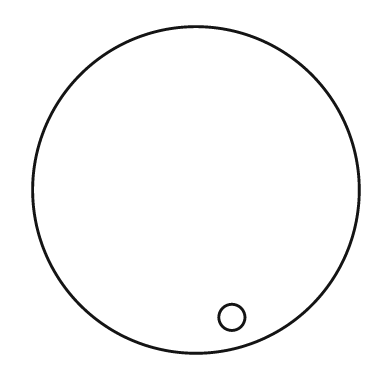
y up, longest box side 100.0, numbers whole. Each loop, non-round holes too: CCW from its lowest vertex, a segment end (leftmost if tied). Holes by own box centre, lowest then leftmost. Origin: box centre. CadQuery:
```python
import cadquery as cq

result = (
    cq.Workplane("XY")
    .moveTo(0.0, 0.0)
    .circle(50.0)
    .moveTo(11.0, -39.0)
    .circle(4.0)
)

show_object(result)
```